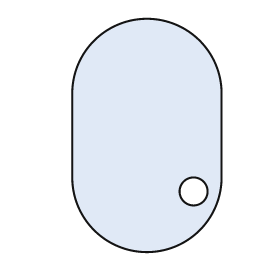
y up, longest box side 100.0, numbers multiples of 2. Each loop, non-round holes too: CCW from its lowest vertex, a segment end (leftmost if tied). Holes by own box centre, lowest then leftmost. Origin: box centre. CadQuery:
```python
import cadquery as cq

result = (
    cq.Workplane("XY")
    .moveTo(-32.0, -18.0)
    .threePointArc((0.0, -50.0), (32.0, -18.0))
    .lineTo(32.0, 18.0)
    .threePointArc((0.0, 50.0), (-32.0, 18.0))
    .close()
    .moveTo(20.0, -24.0)
    .circle(6.0)
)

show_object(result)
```